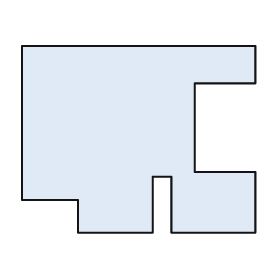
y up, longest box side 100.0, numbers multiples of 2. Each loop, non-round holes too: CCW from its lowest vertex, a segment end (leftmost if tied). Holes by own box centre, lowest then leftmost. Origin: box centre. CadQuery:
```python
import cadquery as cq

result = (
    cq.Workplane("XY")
    .moveTo(-26.0, -40.0)
    .lineTo(6.0, -40.0)
    .lineTo(6.0, -16.0)
    .lineTo(14.0, -16.0)
    .lineTo(14.0, -40.0)
    .lineTo(50.0, -40.0)
    .lineTo(50.0, -14.0)
    .lineTo(24.0, -14.0)
    .lineTo(24.0, 24.0)
    .lineTo(50.0, 24.0)
    .lineTo(50.0, 40.0)
    .lineTo(-50.0, 40.0)
    .lineTo(-50.0, -26.0)
    .lineTo(-26.0, -26.0)
    .close()
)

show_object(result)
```